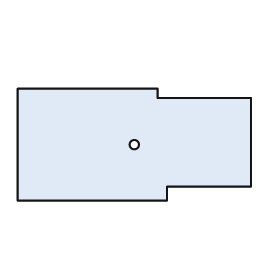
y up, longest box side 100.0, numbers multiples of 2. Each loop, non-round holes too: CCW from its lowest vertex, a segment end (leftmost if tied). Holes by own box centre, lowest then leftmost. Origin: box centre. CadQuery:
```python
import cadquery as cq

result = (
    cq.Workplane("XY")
    .moveTo(-50.0, -24.0)
    .lineTo(14.0, -24.0)
    .lineTo(14.0, -18.0)
    .lineTo(50.0, -18.0)
    .lineTo(50.0, 20.0)
    .lineTo(10.0, 20.0)
    .lineTo(10.0, 24.0)
    .lineTo(-50.0, 24.0)
    .close()
    .moveTo(0.0, 0.0)
    .circle(2.0)
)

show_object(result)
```